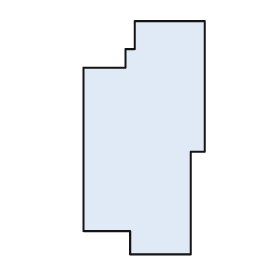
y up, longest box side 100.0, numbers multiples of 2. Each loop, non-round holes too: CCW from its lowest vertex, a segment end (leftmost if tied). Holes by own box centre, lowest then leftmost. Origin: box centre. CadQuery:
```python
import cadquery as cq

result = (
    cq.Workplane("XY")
    .moveTo(-6.0, -50.0)
    .lineTo(20.0, -50.0)
    .lineTo(20.0, -6.0)
    .lineTo(26.0, -6.0)
    .lineTo(26.0, 50.0)
    .lineTo(-4.0, 50.0)
    .lineTo(-4.0, 38.0)
    .lineTo(-8.0, 38.0)
    .lineTo(-8.0, 30.0)
    .lineTo(-26.0, 30.0)
    .lineTo(-26.0, -40.0)
    .lineTo(-6.0, -40.0)
    .close()
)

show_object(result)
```